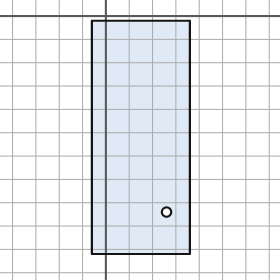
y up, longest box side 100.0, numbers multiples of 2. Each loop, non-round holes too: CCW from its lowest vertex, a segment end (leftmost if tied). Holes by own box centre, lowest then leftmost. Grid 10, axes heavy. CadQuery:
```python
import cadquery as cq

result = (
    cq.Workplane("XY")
    .moveTo(-6.0, -102.0)
    .lineTo(36.0, -102.0)
    .lineTo(36.0, -2.0)
    .lineTo(-6.0, -2.0)
    .close()
    .moveTo(26.0, -84.0)
    .circle(2.0)
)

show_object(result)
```